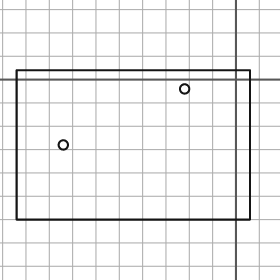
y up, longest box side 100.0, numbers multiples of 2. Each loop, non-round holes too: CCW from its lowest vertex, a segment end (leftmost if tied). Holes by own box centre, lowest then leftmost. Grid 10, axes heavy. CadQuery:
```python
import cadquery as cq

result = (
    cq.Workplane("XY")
    .moveTo(-94.0, -60.0)
    .lineTo(6.0, -60.0)
    .lineTo(6.0, 4.0)
    .lineTo(-94.0, 4.0)
    .close()
    .moveTo(-74.0, -28.0)
    .circle(2.0)
    .moveTo(-22.0, -4.0)
    .circle(2.0)
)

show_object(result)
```